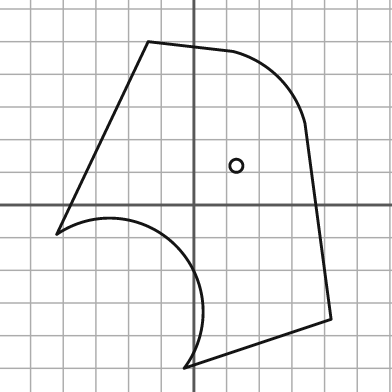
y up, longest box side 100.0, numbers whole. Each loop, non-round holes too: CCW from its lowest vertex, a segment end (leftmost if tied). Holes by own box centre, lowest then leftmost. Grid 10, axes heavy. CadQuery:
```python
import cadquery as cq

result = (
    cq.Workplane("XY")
    .moveTo(-3.0, -50.0)
    .lineTo(42.0, -35.0)
    .lineTo(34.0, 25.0)
    .threePointArc((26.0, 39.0), (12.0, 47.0))
    .lineTo(-14.0, 50.0)
    .lineTo(-42.0, -9.0)
    .threePointArc((-5.0, -13.0), (-3.0, -50.0))
    .close()
    .moveTo(13.0, 12.0)
    .circle(2.0)
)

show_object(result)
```